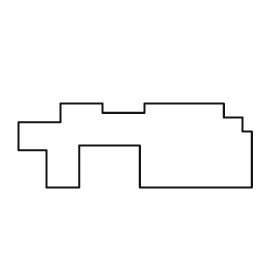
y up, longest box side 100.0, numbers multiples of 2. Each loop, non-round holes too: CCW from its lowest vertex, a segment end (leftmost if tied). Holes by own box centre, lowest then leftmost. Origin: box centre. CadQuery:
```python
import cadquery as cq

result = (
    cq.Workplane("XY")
    .moveTo(-38.0, -18.0)
    .lineTo(-24.0, -18.0)
    .lineTo(-24.0, 0.0)
    .lineTo(2.0, 0.0)
    .lineTo(2.0, -18.0)
    .lineTo(50.0, -18.0)
    .lineTo(50.0, 6.0)
    .lineTo(46.0, 6.0)
    .lineTo(46.0, 12.0)
    .lineTo(38.0, 12.0)
    .lineTo(38.0, 18.0)
    .lineTo(4.0, 18.0)
    .lineTo(4.0, 14.0)
    .lineTo(-14.0, 14.0)
    .lineTo(-14.0, 18.0)
    .lineTo(-32.0, 18.0)
    .lineTo(-32.0, 10.0)
    .lineTo(-50.0, 10.0)
    .lineTo(-50.0, -2.0)
    .lineTo(-38.0, -2.0)
    .close()
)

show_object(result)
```